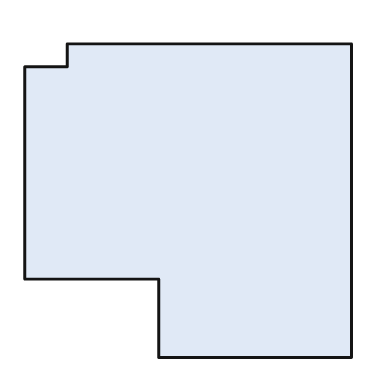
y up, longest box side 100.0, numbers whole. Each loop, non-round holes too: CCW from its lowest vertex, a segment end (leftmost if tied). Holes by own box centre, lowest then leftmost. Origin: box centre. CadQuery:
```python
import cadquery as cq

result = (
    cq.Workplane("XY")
    .moveTo(-9.0, -48.0)
    .lineTo(50.0, -48.0)
    .lineTo(50.0, 48.0)
    .lineTo(-37.0, 48.0)
    .lineTo(-37.0, 41.0)
    .lineTo(-50.0, 41.0)
    .lineTo(-50.0, -24.0)
    .lineTo(-9.0, -24.0)
    .close()
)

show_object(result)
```